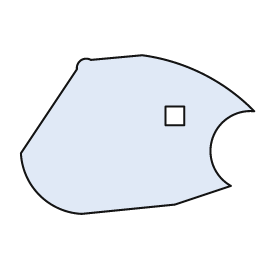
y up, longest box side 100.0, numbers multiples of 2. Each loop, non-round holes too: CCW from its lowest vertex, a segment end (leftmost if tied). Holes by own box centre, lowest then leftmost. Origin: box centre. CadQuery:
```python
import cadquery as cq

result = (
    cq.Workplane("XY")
    .moveTo(-24.0, -34.0)
    .lineTo(16.0, -30.0)
    .lineTo(40.0, -22.0)
    .threePointArc((32.0, -2.0), (50.0, 10.0))
    .threePointArc((28.0, 26.0), (2.0, 34.0))
    .lineTo(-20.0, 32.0)
    .threePointArc((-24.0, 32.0), (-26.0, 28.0))
    .lineTo(-50.0, -8.0)
    .threePointArc((-42.0, -26.0), (-24.0, -34.0))
    .close()
    .moveTo(12.0, 4.0)
    .lineTo(20.0, 4.0)
    .lineTo(20.0, 12.0)
    .lineTo(12.0, 12.0)
    .close()
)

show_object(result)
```